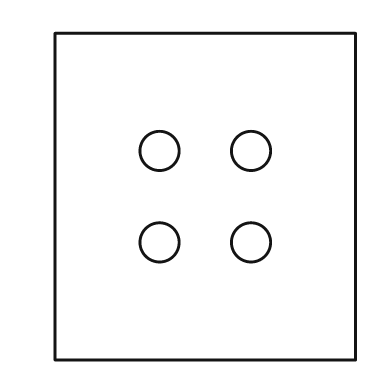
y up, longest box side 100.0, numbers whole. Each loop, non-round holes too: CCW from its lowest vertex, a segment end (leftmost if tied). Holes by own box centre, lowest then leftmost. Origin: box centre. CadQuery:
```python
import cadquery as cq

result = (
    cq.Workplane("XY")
    .moveTo(-46.0, -50.0)
    .lineTo(46.0, -50.0)
    .lineTo(46.0, 50.0)
    .lineTo(-46.0, 50.0)
    .close()
    .moveTo(-14.0, -14.0)
    .circle(6.0)
    .moveTo(14.0, -14.0)
    .circle(6.0)
    .moveTo(-14.0, 14.0)
    .circle(6.0)
    .moveTo(14.0, 14.0)
    .circle(6.0)
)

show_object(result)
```